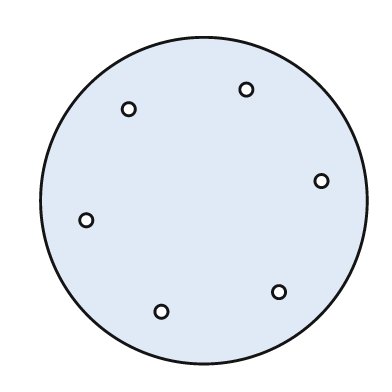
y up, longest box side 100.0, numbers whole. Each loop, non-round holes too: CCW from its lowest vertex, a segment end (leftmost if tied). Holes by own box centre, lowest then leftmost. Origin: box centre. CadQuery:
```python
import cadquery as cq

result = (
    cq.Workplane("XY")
    .moveTo(0.0, 0.0)
    .circle(50.0)
    .moveTo(-13.0, -34.0)
    .circle(2.0)
    .moveTo(23.0, -28.0)
    .circle(2.0)
    .moveTo(-36.0, -6.0)
    .circle(2.0)
    .moveTo(36.0, 6.0)
    .circle(2.0)
    .moveTo(-23.0, 28.0)
    .circle(2.0)
    .moveTo(13.0, 34.0)
    .circle(2.0)
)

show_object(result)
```